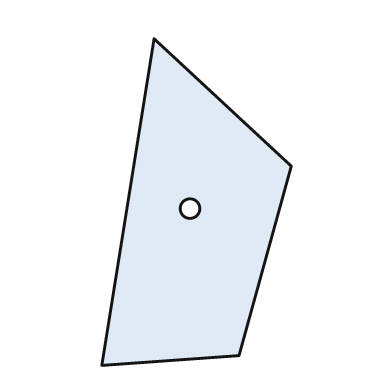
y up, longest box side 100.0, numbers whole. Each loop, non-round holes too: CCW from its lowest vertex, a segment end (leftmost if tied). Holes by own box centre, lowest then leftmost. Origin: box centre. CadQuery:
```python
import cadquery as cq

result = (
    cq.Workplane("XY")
    .moveTo(-29.0, -50.0)
    .lineTo(13.0, -47.0)
    .lineTo(29.0, 11.0)
    .lineTo(-13.0, 50.0)
    .close()
    .moveTo(-2.0, -2.0)
    .circle(3.0)
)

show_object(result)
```